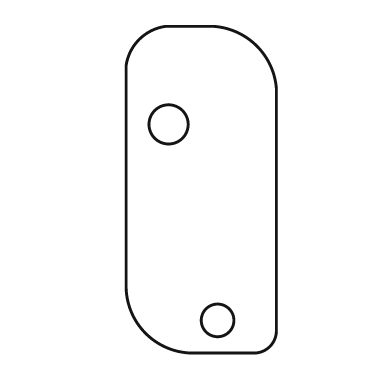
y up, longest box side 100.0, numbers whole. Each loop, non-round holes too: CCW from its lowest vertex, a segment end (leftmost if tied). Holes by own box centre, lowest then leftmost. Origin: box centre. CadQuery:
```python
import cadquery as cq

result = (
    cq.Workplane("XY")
    .moveTo(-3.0, -50.0)
    .lineTo(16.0, -50.0)
    .threePointArc((21.0, -48.0), (23.0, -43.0))
    .lineTo(23.0, 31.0)
    .threePointArc((17.0, 44.0), (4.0, 50.0))
    .lineTo(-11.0, 50.0)
    .threePointArc((-19.0, 46.0), (-23.0, 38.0))
    .lineTo(-23.0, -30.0)
    .threePointArc((-17.0, -44.0), (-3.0, -50.0))
    .close()
    .moveTo(5.0, -40.0)
    .circle(5.0)
    .moveTo(-10.0, 20.0)
    .circle(6.0)
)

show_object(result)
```